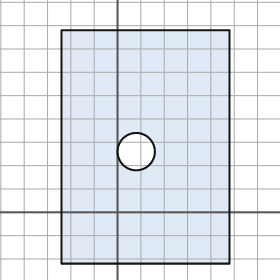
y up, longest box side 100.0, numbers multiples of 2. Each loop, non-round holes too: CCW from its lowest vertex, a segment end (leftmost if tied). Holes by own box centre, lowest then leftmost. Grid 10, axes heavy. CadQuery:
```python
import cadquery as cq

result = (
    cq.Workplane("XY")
    .moveTo(-24.0, -22.0)
    .lineTo(48.0, -22.0)
    .lineTo(48.0, 78.0)
    .lineTo(-24.0, 78.0)
    .close()
    .moveTo(8.0, 26.0)
    .circle(8.0)
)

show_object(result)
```